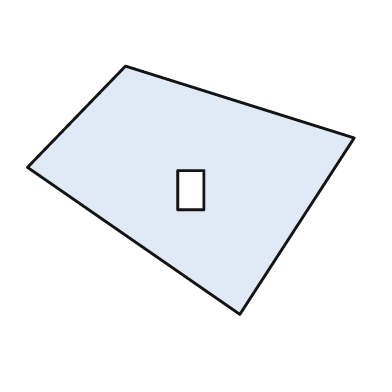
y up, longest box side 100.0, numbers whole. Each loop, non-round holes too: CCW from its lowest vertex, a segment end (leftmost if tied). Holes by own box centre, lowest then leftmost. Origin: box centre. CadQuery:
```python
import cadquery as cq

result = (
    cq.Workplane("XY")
    .moveTo(15.0, -38.0)
    .lineTo(50.0, 16.0)
    .lineTo(-20.0, 38.0)
    .lineTo(-50.0, 7.0)
    .close()
    .moveTo(-4.0, -6.0)
    .lineTo(4.0, -6.0)
    .lineTo(4.0, 6.0)
    .lineTo(-4.0, 6.0)
    .close()
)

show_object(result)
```